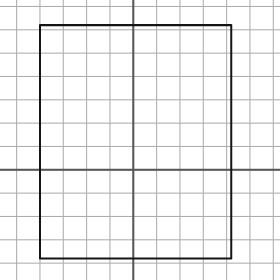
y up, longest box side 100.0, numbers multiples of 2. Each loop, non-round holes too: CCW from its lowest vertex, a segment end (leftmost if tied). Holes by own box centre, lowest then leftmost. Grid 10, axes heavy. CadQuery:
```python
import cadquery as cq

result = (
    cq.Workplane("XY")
    .moveTo(-40.0, -38.0)
    .lineTo(42.0, -38.0)
    .lineTo(42.0, 62.0)
    .lineTo(-40.0, 62.0)
    .close()
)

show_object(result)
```